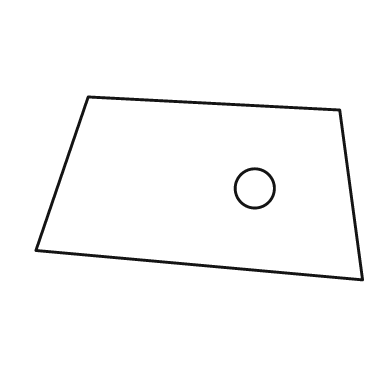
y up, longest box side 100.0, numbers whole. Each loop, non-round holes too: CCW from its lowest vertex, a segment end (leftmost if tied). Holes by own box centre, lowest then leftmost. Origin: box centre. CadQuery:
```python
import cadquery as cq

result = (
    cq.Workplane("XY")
    .moveTo(50.0, -28.0)
    .lineTo(43.0, 24.0)
    .lineTo(-34.0, 28.0)
    .lineTo(-50.0, -19.0)
    .close()
    .moveTo(17.0, 0.0)
    .circle(6.0)
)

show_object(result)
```